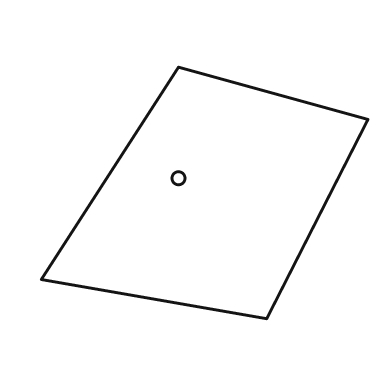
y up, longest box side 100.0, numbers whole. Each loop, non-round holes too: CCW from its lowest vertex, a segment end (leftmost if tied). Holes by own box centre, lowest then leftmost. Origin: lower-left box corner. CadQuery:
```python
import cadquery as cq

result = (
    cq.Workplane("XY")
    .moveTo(69.0, 0.0)
    .lineTo(100.0, 61.0)
    .lineTo(42.0, 77.0)
    .lineTo(0.0, 12.0)
    .close()
    .moveTo(42.0, 43.0)
    .circle(2.0)
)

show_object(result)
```